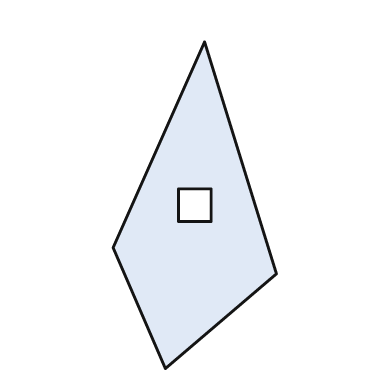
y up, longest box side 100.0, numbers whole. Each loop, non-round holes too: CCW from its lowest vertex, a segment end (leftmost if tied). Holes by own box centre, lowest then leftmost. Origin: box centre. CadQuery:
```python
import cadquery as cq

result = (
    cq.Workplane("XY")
    .moveTo(-9.0, -50.0)
    .lineTo(25.0, -21.0)
    .lineTo(3.0, 50.0)
    .lineTo(-25.0, -13.0)
    .close()
    .moveTo(-5.0, -5.0)
    .lineTo(5.0, -5.0)
    .lineTo(5.0, 5.0)
    .lineTo(-5.0, 5.0)
    .close()
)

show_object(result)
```